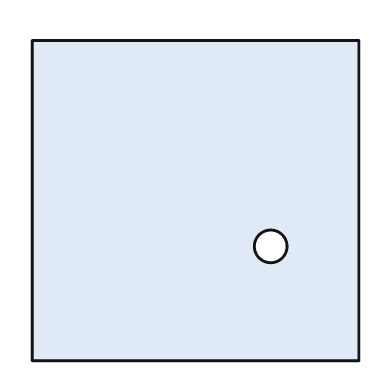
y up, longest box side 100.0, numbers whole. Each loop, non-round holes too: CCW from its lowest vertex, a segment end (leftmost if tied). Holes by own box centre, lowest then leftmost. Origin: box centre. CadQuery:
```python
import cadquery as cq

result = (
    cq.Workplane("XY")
    .moveTo(-50.0, -49.0)
    .lineTo(50.0, -49.0)
    .lineTo(50.0, 49.0)
    .lineTo(-50.0, 49.0)
    .close()
    .moveTo(23.0, -14.0)
    .circle(5.0)
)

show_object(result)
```